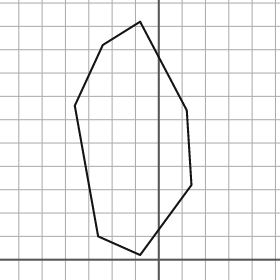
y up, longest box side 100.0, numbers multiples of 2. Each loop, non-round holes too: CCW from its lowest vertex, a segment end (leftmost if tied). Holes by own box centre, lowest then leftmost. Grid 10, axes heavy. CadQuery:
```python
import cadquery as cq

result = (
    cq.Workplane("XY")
    .moveTo(-8.0, 2.0)
    .lineTo(14.0, 32.0)
    .lineTo(12.0, 64.0)
    .lineTo(-8.0, 102.0)
    .lineTo(-24.0, 92.0)
    .lineTo(-36.0, 66.0)
    .lineTo(-26.0, 10.0)
    .close()
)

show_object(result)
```